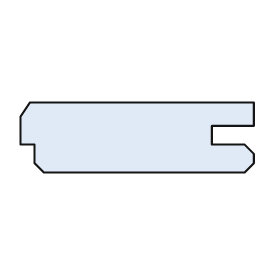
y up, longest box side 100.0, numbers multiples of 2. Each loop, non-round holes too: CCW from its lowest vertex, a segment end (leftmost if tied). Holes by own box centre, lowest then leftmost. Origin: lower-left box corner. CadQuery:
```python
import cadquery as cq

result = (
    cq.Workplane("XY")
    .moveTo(10.0, 0.0)
    .lineTo(96.0, 0.0)
    .lineTo(100.0, 4.0)
    .lineTo(100.0, 8.0)
    .lineTo(96.0, 12.0)
    .lineTo(82.0, 12.0)
    .lineTo(82.0, 20.0)
    .lineTo(100.0, 20.0)
    .lineTo(100.0, 30.0)
    .lineTo(4.0, 30.0)
    .lineTo(0.0, 24.0)
    .lineTo(0.0, 12.0)
    .lineTo(6.0, 12.0)
    .lineTo(6.0, 4.0)
    .close()
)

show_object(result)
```